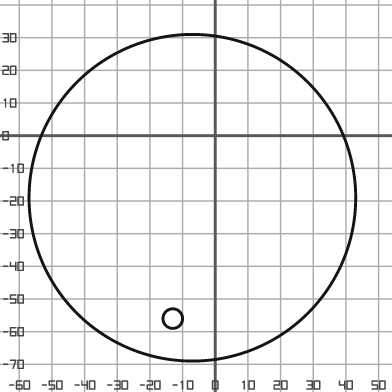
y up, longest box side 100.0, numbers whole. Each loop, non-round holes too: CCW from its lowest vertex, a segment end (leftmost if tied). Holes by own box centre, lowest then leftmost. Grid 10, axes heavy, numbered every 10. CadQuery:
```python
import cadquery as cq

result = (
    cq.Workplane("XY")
    .moveTo(-7.0, -19.0)
    .circle(50.0)
    .moveTo(-13.0, -56.0)
    .circle(3.0)
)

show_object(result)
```